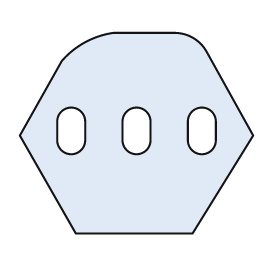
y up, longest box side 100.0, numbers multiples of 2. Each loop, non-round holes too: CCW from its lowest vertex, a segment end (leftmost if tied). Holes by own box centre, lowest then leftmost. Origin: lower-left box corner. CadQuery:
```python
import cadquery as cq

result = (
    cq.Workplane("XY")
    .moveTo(24.0, 0.0)
    .lineTo(74.0, 0.0)
    .lineTo(100.0, 42.0)
    .lineTo(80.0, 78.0)
    .threePointArc((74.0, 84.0), (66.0, 86.0))
    .lineTo(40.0, 86.0)
    .threePointArc((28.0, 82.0), (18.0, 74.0))
    .lineTo(0.0, 42.0)
    .close()
    .moveTo(16.0, 40.0)
    .threePointArc((22.0, 34.0), (28.0, 40.0))
    .lineTo(28.0, 48.0)
    .threePointArc((22.0, 54.0), (16.0, 48.0))
    .close()
    .moveTo(44.0, 40.0)
    .threePointArc((50.0, 34.0), (56.0, 40.0))
    .lineTo(56.0, 48.0)
    .threePointArc((50.0, 54.0), (44.0, 48.0))
    .close()
    .moveTo(72.0, 40.0)
    .threePointArc((78.0, 34.0), (84.0, 40.0))
    .lineTo(84.0, 48.0)
    .threePointArc((78.0, 54.0), (72.0, 48.0))
    .close()
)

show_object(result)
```